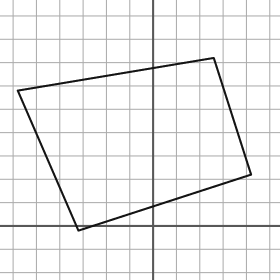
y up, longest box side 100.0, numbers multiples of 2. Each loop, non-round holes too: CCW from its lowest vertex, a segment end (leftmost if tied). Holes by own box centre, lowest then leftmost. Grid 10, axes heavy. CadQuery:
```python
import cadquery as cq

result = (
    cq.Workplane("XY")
    .moveTo(-32.0, -2.0)
    .lineTo(42.0, 22.0)
    .lineTo(26.0, 72.0)
    .lineTo(-58.0, 58.0)
    .close()
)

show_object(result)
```